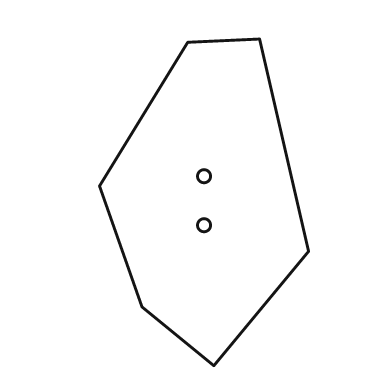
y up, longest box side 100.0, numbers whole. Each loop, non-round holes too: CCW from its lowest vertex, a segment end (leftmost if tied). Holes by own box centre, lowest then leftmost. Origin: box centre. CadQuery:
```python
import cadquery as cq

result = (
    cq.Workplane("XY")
    .moveTo(3.0, -50.0)
    .lineTo(32.0, -15.0)
    .lineTo(17.0, 50.0)
    .lineTo(-5.0, 49.0)
    .lineTo(-32.0, 5.0)
    .lineTo(-19.0, -32.0)
    .close()
    .moveTo(0.0, -7.0)
    .circle(2.0)
    .moveTo(0.0, 8.0)
    .circle(2.0)
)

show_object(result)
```